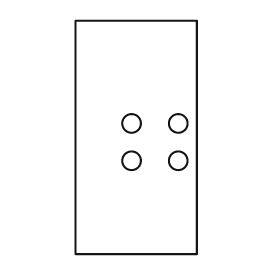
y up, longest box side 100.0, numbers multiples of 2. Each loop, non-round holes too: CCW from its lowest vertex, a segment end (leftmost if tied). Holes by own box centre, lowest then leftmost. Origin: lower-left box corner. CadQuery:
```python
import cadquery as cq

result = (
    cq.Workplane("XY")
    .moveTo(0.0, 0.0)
    .lineTo(52.0, 0.0)
    .lineTo(52.0, 100.0)
    .lineTo(0.0, 100.0)
    .close()
    .moveTo(24.0, 40.0)
    .circle(4.0)
    .moveTo(44.0, 40.0)
    .circle(4.0)
    .moveTo(24.0, 56.0)
    .circle(4.0)
    .moveTo(44.0, 56.0)
    .circle(4.0)
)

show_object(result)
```